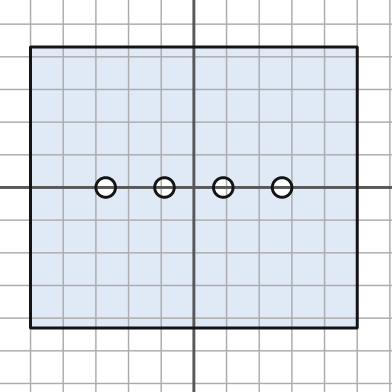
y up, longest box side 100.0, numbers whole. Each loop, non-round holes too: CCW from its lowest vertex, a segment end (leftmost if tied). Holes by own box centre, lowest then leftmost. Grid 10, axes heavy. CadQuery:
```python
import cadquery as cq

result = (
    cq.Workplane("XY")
    .moveTo(-50.0, -43.0)
    .lineTo(50.0, -43.0)
    .lineTo(50.0, 43.0)
    .lineTo(-50.0, 43.0)
    .close()
    .moveTo(-27.0, 0.0)
    .circle(3.0)
    .moveTo(-9.0, 0.0)
    .circle(3.0)
    .moveTo(9.0, 0.0)
    .circle(3.0)
    .moveTo(27.0, 0.0)
    .circle(3.0)
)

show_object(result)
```